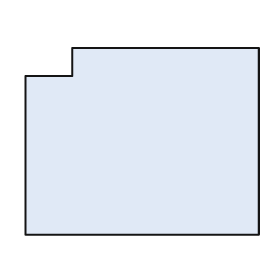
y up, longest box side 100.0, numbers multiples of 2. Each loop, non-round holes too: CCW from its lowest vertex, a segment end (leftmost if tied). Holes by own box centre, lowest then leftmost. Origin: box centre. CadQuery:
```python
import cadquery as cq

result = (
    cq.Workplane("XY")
    .moveTo(-50.0, -40.0)
    .lineTo(50.0, -40.0)
    .lineTo(50.0, 40.0)
    .lineTo(-30.0, 40.0)
    .lineTo(-30.0, 28.0)
    .lineTo(-50.0, 28.0)
    .close()
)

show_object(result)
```